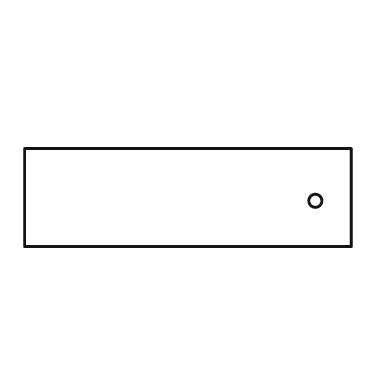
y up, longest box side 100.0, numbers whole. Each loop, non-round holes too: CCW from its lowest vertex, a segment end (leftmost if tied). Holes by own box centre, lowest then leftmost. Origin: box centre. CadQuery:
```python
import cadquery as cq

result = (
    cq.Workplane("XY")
    .moveTo(-50.0, -15.0)
    .lineTo(50.0, -15.0)
    .lineTo(50.0, 15.0)
    .lineTo(-50.0, 15.0)
    .close()
    .moveTo(39.0, -1.0)
    .circle(2.0)
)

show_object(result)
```